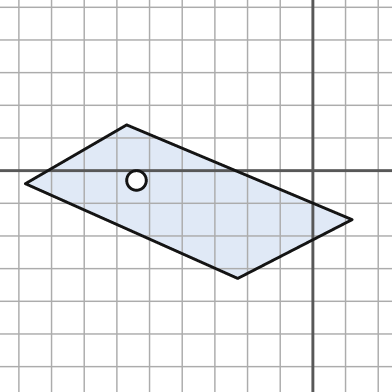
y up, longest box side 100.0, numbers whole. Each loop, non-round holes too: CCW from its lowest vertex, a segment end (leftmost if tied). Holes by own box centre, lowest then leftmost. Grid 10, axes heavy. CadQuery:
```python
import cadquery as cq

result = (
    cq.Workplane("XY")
    .moveTo(-23.0, -33.0)
    .lineTo(12.0, -15.0)
    .lineTo(-57.0, 14.0)
    .lineTo(-88.0, -4.0)
    .close()
    .moveTo(-54.0, -3.0)
    .circle(3.0)
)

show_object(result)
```